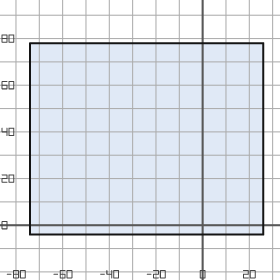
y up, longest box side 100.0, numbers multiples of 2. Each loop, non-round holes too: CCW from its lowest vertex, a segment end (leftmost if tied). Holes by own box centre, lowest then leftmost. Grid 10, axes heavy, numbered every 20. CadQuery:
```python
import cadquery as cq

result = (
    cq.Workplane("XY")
    .moveTo(-74.0, -4.0)
    .lineTo(26.0, -4.0)
    .lineTo(26.0, 78.0)
    .lineTo(-74.0, 78.0)
    .close()
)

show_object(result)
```